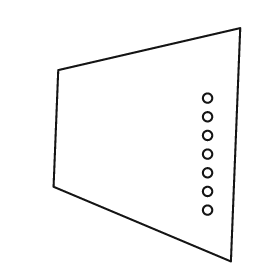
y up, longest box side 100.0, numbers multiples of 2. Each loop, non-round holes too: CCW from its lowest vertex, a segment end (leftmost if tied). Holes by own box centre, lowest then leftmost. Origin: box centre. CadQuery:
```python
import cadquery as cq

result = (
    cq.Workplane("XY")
    .moveTo(36.0, -50.0)
    .lineTo(40.0, 50.0)
    .lineTo(-38.0, 32.0)
    .lineTo(-40.0, -18.0)
    .close()
    .moveTo(26.0, -28.0)
    .circle(2.0)
    .moveTo(26.0, -20.0)
    .circle(2.0)
    .moveTo(26.0, -12.0)
    .circle(2.0)
    .moveTo(26.0, -4.0)
    .circle(2.0)
    .moveTo(26.0, 4.0)
    .circle(2.0)
    .moveTo(26.0, 12.0)
    .circle(2.0)
    .moveTo(26.0, 20.0)
    .circle(2.0)
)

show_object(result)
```